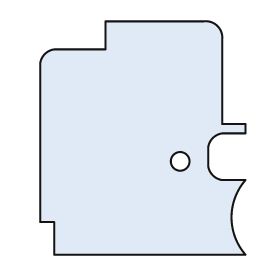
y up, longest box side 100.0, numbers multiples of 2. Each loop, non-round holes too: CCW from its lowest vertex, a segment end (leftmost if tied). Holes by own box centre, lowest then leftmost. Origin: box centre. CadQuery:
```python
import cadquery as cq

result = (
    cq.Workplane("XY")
    .moveTo(-38.0, -50.0)
    .lineTo(44.0, -50.0)
    .threePointArc((38.0, -34.0), (44.0, -18.0))
    .lineTo(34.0, -18.0)
    .threePointArc((30.0, -16.0), (28.0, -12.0))
    .lineTo(28.0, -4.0)
    .threePointArc((30.0, 0.0), (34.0, 2.0))
    .lineTo(44.0, 2.0)
    .lineTo(44.0, 6.0)
    .lineTo(34.0, 6.0)
    .lineTo(34.0, 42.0)
    .threePointArc((32.0, 48.0), (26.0, 50.0))
    .lineTo(-16.0, 50.0)
    .lineTo(-16.0, 38.0)
    .lineTo(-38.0, 38.0)
    .threePointArc((-42.0, 36.0), (-44.0, 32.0))
    .lineTo(-44.0, -36.0)
    .lineTo(-38.0, -36.0)
    .close()
    .moveTo(16.0, -10.0)
    .circle(4.0)
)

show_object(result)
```